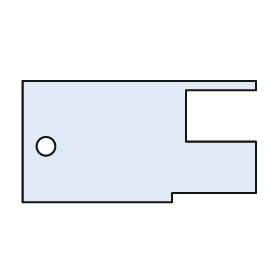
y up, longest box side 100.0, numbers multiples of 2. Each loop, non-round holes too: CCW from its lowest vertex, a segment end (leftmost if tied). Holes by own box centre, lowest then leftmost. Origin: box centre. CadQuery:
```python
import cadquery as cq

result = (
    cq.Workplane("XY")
    .moveTo(-50.0, -26.0)
    .lineTo(14.0, -26.0)
    .lineTo(14.0, -22.0)
    .lineTo(50.0, -22.0)
    .lineTo(50.0, 0.0)
    .lineTo(20.0, 0.0)
    .lineTo(20.0, 22.0)
    .lineTo(50.0, 22.0)
    .lineTo(50.0, 26.0)
    .lineTo(-50.0, 26.0)
    .close()
    .moveTo(-40.0, -2.0)
    .circle(4.0)
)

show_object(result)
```